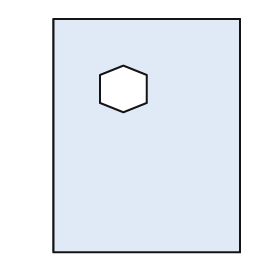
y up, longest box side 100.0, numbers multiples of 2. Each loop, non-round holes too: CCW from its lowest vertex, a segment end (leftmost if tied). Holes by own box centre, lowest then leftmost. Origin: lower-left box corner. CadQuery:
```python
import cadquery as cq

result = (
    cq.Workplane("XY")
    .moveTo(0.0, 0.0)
    .lineTo(80.0, 0.0)
    .lineTo(80.0, 100.0)
    .lineTo(0.0, 100.0)
    .close()
    .moveTo(30.0, 60.0)
    .lineTo(40.0, 64.0)
    .lineTo(40.0, 76.0)
    .lineTo(30.0, 80.0)
    .lineTo(20.0, 76.0)
    .lineTo(20.0, 64.0)
    .close()
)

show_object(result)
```